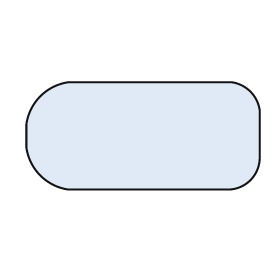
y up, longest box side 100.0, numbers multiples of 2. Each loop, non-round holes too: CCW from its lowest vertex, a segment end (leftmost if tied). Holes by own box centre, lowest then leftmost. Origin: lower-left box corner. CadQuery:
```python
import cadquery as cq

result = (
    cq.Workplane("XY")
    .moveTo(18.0, 0.0)
    .lineTo(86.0, 0.0)
    .threePointArc((96.0, 4.0), (100.0, 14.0))
    .lineTo(100.0, 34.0)
    .threePointArc((96.0, 42.0), (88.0, 46.0))
    .lineTo(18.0, 46.0)
    .threePointArc((6.0, 40.0), (0.0, 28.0))
    .lineTo(0.0, 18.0)
    .threePointArc((6.0, 6.0), (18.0, 0.0))
    .close()
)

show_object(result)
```